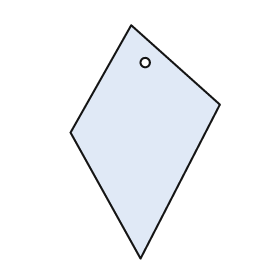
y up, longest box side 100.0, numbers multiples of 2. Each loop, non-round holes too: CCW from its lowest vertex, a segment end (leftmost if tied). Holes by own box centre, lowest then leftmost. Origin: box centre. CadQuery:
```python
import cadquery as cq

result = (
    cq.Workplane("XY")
    .moveTo(-2.0, -50.0)
    .lineTo(32.0, 16.0)
    .lineTo(-6.0, 50.0)
    .lineTo(-32.0, 4.0)
    .close()
    .moveTo(0.0, 34.0)
    .circle(2.0)
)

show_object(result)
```